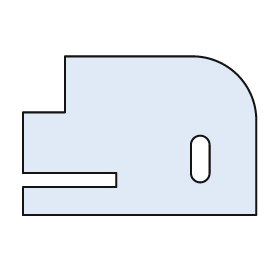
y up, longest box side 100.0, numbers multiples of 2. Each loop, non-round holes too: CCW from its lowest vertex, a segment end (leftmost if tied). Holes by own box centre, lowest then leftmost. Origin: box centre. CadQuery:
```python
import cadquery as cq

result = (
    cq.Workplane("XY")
    .moveTo(-50.0, -34.0)
    .lineTo(50.0, -34.0)
    .lineTo(50.0, 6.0)
    .threePointArc((42.0, 26.0), (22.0, 34.0))
    .lineTo(-32.0, 34.0)
    .lineTo(-32.0, 10.0)
    .lineTo(-50.0, 10.0)
    .lineTo(-50.0, -16.0)
    .lineTo(-10.0, -16.0)
    .lineTo(-10.0, -22.0)
    .lineTo(-50.0, -22.0)
    .close()
    .moveTo(22.0, -16.0)
    .threePointArc((26.0, -20.0), (30.0, -16.0))
    .lineTo(30.0, -4.0)
    .threePointArc((26.0, 0.0), (22.0, -4.0))
    .close()
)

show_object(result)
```